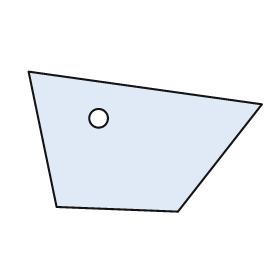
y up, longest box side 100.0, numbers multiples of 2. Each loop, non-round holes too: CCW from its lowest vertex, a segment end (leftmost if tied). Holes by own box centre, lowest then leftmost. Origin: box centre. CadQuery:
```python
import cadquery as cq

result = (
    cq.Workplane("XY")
    .moveTo(14.0, -30.0)
    .lineTo(50.0, 16.0)
    .lineTo(-50.0, 30.0)
    .lineTo(-38.0, -28.0)
    .close()
    .moveTo(-20.0, 10.0)
    .circle(4.0)
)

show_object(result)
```